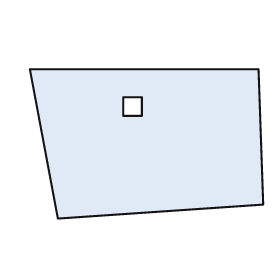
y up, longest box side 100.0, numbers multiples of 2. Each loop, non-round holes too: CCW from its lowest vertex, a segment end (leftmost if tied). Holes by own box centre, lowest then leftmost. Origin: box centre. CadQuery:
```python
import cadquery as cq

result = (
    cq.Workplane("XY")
    .moveTo(-38.0, -32.0)
    .lineTo(50.0, -26.0)
    .lineTo(48.0, 32.0)
    .lineTo(-50.0, 32.0)
    .close()
    .moveTo(-10.0, 12.0)
    .lineTo(-2.0, 12.0)
    .lineTo(-2.0, 20.0)
    .lineTo(-10.0, 20.0)
    .close()
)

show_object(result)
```